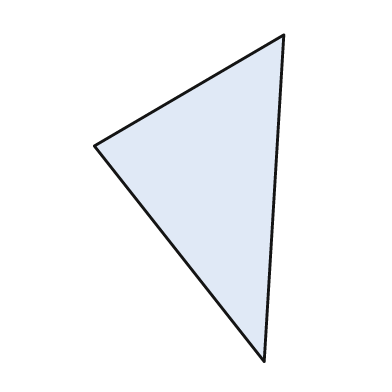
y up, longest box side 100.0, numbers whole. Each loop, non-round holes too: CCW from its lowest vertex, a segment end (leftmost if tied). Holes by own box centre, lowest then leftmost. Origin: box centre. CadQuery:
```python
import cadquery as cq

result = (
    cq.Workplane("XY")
    .moveTo(23.0, -50.0)
    .lineTo(29.0, 50.0)
    .lineTo(-29.0, 16.0)
    .close()
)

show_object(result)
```